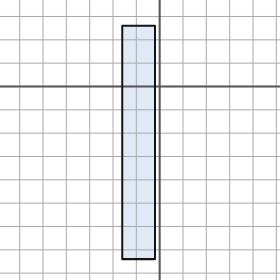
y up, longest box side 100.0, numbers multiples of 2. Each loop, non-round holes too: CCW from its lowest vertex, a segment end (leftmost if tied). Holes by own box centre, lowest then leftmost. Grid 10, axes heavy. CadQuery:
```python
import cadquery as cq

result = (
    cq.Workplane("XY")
    .moveTo(-16.0, -74.0)
    .lineTo(-2.0, -74.0)
    .lineTo(-2.0, 26.0)
    .lineTo(-16.0, 26.0)
    .close()
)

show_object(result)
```